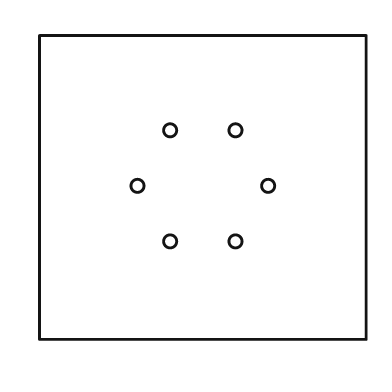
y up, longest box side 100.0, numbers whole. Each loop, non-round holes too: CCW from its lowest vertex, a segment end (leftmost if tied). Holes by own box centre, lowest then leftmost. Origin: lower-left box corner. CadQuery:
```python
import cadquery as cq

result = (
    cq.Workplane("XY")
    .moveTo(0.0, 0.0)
    .lineTo(100.0, 0.0)
    .lineTo(100.0, 93.0)
    .lineTo(0.0, 93.0)
    .close()
    .moveTo(40.0, 30.0)
    .circle(2.0)
    .moveTo(60.0, 30.0)
    .circle(2.0)
    .moveTo(30.0, 47.0)
    .circle(2.0)
    .moveTo(70.0, 47.0)
    .circle(2.0)
    .moveTo(40.0, 64.0)
    .circle(2.0)
    .moveTo(60.0, 64.0)
    .circle(2.0)
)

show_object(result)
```